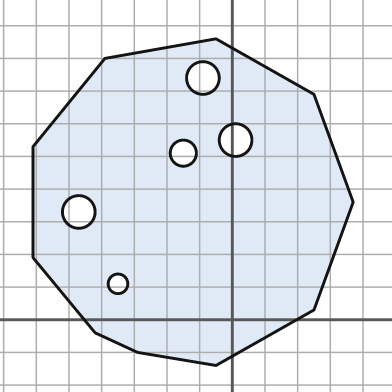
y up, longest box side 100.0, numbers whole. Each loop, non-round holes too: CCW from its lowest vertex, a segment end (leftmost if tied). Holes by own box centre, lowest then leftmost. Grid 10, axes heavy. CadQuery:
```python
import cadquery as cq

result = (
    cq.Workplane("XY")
    .moveTo(-5.0, -14.0)
    .lineTo(25.0, 3.0)
    .lineTo(37.0, 36.0)
    .lineTo(25.0, 69.0)
    .lineTo(-5.0, 86.0)
    .lineTo(-39.0, 80.0)
    .lineTo(-61.0, 53.0)
    .lineTo(-61.0, 19.0)
    .lineTo(-42.0, -4.0)
    .lineTo(-29.0, -10.0)
    .close()
    .moveTo(-35.0, 11.0)
    .circle(3.0)
    .moveTo(-47.0, 33.0)
    .circle(5.0)
    .moveTo(-15.0, 51.0)
    .circle(4.0)
    .moveTo(1.0, 55.0)
    .circle(5.0)
    .moveTo(-9.0, 74.0)
    .circle(5.0)
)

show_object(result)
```